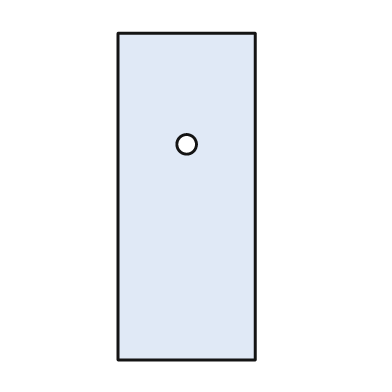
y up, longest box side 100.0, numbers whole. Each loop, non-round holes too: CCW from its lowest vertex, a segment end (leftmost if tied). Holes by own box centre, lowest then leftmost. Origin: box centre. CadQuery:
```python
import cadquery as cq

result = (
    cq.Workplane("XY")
    .moveTo(-21.0, -50.0)
    .lineTo(21.0, -50.0)
    .lineTo(21.0, 50.0)
    .lineTo(-21.0, 50.0)
    .close()
    .moveTo(0.0, 16.0)
    .circle(3.0)
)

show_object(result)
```